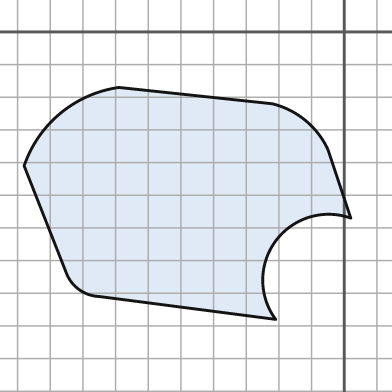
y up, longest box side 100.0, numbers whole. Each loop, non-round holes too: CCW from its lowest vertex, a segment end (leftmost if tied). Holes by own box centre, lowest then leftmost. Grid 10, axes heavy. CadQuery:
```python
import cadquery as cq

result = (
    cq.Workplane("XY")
    .moveTo(-21.0, -88.0)
    .threePointArc((-21.0, -64.0), (2.0, -57.0))
    .lineTo(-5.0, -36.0)
    .threePointArc((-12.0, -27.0), (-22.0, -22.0))
    .lineTo(-69.0, -17.0)
    .threePointArc((-87.0, -25.0), (-98.0, -41.0))
    .lineTo(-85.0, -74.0)
    .threePointArc((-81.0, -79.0), (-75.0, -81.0))
    .close()
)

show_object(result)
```